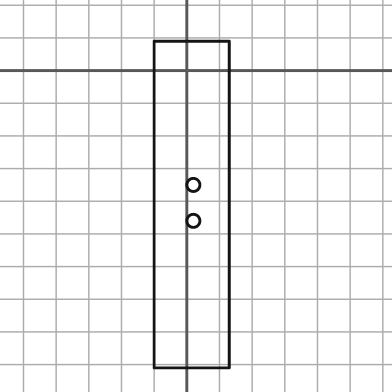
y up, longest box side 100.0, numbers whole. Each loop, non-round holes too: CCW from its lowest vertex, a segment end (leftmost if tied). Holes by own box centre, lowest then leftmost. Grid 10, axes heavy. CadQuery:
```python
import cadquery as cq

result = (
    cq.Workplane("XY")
    .moveTo(-10.0, -91.0)
    .lineTo(13.0, -91.0)
    .lineTo(13.0, 9.0)
    .lineTo(-10.0, 9.0)
    .close()
    .moveTo(2.0, -46.0)
    .circle(2.0)
    .moveTo(2.0, -35.0)
    .circle(2.0)
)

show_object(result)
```